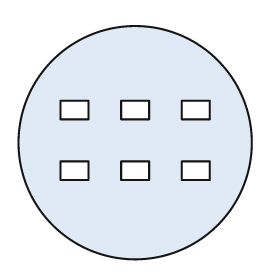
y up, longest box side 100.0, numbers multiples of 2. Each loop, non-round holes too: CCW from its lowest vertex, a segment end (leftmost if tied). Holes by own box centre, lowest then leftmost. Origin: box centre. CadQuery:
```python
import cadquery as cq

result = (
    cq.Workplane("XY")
    .moveTo(0.0, 0.0)
    .circle(50.0)
    .moveTo(-32.0, -16.0)
    .lineTo(-20.0, -16.0)
    .lineTo(-20.0, -8.0)
    .lineTo(-32.0, -8.0)
    .close()
    .moveTo(-6.0, -16.0)
    .lineTo(6.0, -16.0)
    .lineTo(6.0, -8.0)
    .lineTo(-6.0, -8.0)
    .close()
    .moveTo(20.0, -16.0)
    .lineTo(32.0, -16.0)
    .lineTo(32.0, -8.0)
    .lineTo(20.0, -8.0)
    .close()
    .moveTo(-32.0, 10.0)
    .lineTo(-20.0, 10.0)
    .lineTo(-20.0, 18.0)
    .lineTo(-32.0, 18.0)
    .close()
    .moveTo(-6.0, 10.0)
    .lineTo(6.0, 10.0)
    .lineTo(6.0, 18.0)
    .lineTo(-6.0, 18.0)
    .close()
    .moveTo(20.0, 10.0)
    .lineTo(32.0, 10.0)
    .lineTo(32.0, 18.0)
    .lineTo(20.0, 18.0)
    .close()
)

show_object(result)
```